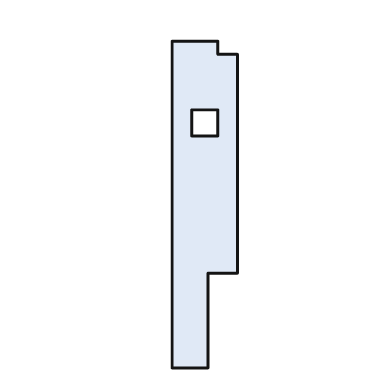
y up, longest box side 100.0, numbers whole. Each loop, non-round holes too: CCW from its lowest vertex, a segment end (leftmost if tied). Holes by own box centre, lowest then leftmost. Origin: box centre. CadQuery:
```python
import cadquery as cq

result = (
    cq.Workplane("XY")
    .moveTo(-10.0, -50.0)
    .lineTo(1.0, -50.0)
    .lineTo(1.0, -21.0)
    .lineTo(10.0, -21.0)
    .lineTo(10.0, 46.0)
    .lineTo(4.0, 46.0)
    .lineTo(4.0, 50.0)
    .lineTo(-10.0, 50.0)
    .close()
    .moveTo(-4.0, 21.0)
    .lineTo(4.0, 21.0)
    .lineTo(4.0, 29.0)
    .lineTo(-4.0, 29.0)
    .close()
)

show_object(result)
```